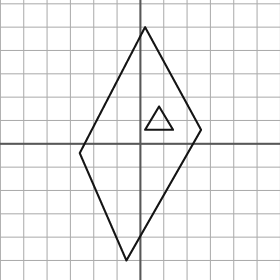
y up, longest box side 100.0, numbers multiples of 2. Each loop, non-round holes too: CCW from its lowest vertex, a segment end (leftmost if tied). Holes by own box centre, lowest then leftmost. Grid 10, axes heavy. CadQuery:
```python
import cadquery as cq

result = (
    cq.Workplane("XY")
    .moveTo(-6.0, -50.0)
    .lineTo(26.0, 6.0)
    .lineTo(2.0, 50.0)
    .lineTo(-26.0, -4.0)
    .close()
    .moveTo(2.0, 6.0)
    .lineTo(14.0, 6.0)
    .lineTo(8.0, 16.0)
    .close()
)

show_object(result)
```